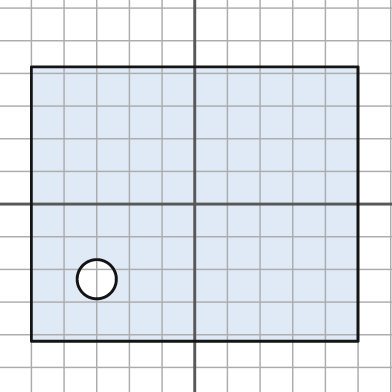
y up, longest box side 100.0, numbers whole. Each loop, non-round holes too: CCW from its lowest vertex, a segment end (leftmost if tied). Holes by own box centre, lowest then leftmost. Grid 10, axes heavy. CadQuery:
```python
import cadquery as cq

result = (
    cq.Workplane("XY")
    .moveTo(-50.0, -42.0)
    .lineTo(50.0, -42.0)
    .lineTo(50.0, 42.0)
    .lineTo(-50.0, 42.0)
    .close()
    .moveTo(-30.0, -23.0)
    .circle(6.0)
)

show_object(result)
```